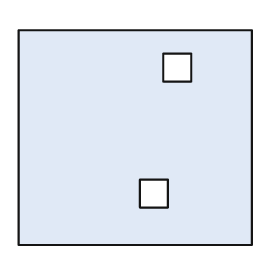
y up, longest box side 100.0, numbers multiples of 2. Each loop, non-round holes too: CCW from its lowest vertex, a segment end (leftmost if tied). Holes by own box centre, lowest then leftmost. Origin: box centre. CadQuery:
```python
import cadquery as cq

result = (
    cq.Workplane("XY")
    .moveTo(-50.0, -46.0)
    .lineTo(50.0, -46.0)
    .lineTo(50.0, 46.0)
    .lineTo(-50.0, 46.0)
    .close()
    .moveTo(2.0, -30.0)
    .lineTo(14.0, -30.0)
    .lineTo(14.0, -18.0)
    .lineTo(2.0, -18.0)
    .close()
    .moveTo(12.0, 24.0)
    .lineTo(24.0, 24.0)
    .lineTo(24.0, 36.0)
    .lineTo(12.0, 36.0)
    .close()
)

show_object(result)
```